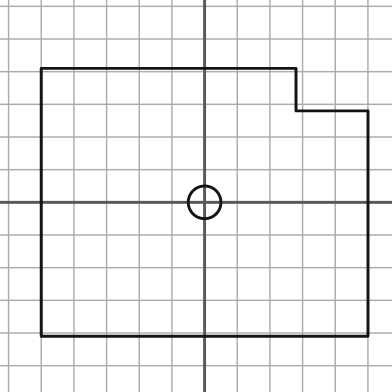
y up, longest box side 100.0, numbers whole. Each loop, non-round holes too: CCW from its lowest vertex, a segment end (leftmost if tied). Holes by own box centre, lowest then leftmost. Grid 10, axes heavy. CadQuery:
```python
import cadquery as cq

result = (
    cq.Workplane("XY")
    .moveTo(-50.0, -41.0)
    .lineTo(50.0, -41.0)
    .lineTo(50.0, 28.0)
    .lineTo(28.0, 28.0)
    .lineTo(28.0, 41.0)
    .lineTo(-50.0, 41.0)
    .close()
    .moveTo(0.0, 0.0)
    .circle(5.0)
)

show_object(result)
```